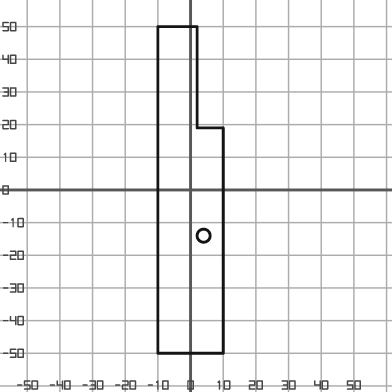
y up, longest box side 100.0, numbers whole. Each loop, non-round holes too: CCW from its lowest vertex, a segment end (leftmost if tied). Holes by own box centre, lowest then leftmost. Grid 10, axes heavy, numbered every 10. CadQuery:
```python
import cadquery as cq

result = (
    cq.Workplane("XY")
    .moveTo(-10.0, -50.0)
    .lineTo(10.0, -50.0)
    .lineTo(10.0, 19.0)
    .lineTo(2.0, 19.0)
    .lineTo(2.0, 50.0)
    .lineTo(-10.0, 50.0)
    .close()
    .moveTo(4.0, -14.0)
    .circle(2.0)
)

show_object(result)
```